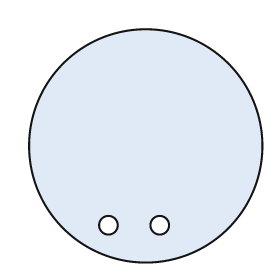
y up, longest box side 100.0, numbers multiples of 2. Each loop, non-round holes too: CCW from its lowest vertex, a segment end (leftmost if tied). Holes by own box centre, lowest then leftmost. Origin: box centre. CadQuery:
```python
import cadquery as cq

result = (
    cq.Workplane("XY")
    .moveTo(0.0, 0.0)
    .circle(50.0)
    .moveTo(-16.0, -34.0)
    .circle(4.0)
    .moveTo(6.0, -34.0)
    .circle(4.0)
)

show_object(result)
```